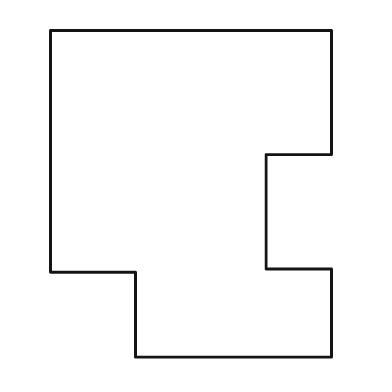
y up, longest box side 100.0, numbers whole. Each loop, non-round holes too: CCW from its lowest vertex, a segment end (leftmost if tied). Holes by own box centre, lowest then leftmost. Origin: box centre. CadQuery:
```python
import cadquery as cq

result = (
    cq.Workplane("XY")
    .moveTo(-17.0, -50.0)
    .lineTo(43.0, -50.0)
    .lineTo(43.0, -23.0)
    .lineTo(23.0, -23.0)
    .lineTo(23.0, 12.0)
    .lineTo(43.0, 12.0)
    .lineTo(43.0, 50.0)
    .lineTo(-43.0, 50.0)
    .lineTo(-43.0, -24.0)
    .lineTo(-17.0, -24.0)
    .close()
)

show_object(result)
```